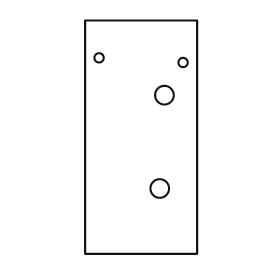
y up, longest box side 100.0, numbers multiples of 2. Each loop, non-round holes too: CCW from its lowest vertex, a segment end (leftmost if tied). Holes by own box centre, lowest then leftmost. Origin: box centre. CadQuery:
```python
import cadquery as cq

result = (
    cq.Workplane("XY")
    .moveTo(-24.0, -50.0)
    .lineTo(24.0, -50.0)
    .lineTo(24.0, 50.0)
    .lineTo(-24.0, 50.0)
    .close()
    .moveTo(8.0, -22.0)
    .circle(4.0)
    .moveTo(10.0, 18.0)
    .circle(4.0)
    .moveTo(18.0, 32.0)
    .circle(2.0)
    .moveTo(-18.0, 34.0)
    .circle(2.0)
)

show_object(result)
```